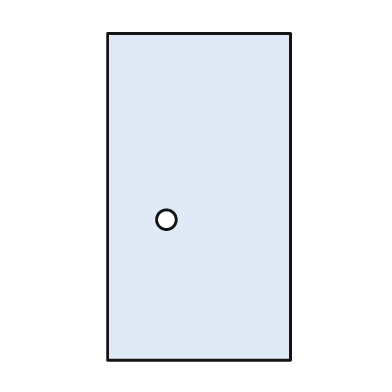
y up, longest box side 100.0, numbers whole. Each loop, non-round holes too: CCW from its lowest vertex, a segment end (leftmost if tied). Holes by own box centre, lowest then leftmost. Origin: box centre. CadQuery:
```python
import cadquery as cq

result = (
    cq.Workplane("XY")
    .moveTo(-28.0, -50.0)
    .lineTo(28.0, -50.0)
    .lineTo(28.0, 50.0)
    .lineTo(-28.0, 50.0)
    .close()
    .moveTo(-10.0, -7.0)
    .circle(3.0)
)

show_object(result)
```